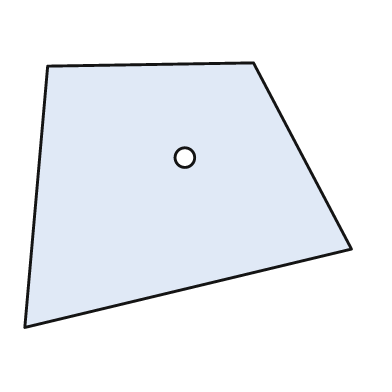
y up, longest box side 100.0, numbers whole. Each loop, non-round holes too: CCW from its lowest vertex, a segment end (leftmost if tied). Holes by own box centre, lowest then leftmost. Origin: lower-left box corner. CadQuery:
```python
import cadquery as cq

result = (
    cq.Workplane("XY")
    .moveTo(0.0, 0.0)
    .lineTo(100.0, 24.0)
    .lineTo(70.0, 81.0)
    .lineTo(7.0, 80.0)
    .close()
    .moveTo(49.0, 52.0)
    .circle(3.0)
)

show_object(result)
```